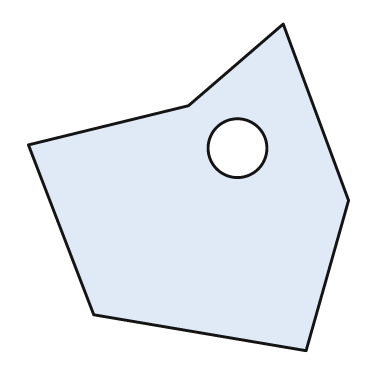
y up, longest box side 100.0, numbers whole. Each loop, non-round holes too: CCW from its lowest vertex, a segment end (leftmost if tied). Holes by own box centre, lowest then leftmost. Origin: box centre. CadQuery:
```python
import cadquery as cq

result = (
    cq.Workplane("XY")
    .moveTo(36.0, -50.0)
    .lineTo(49.0, -4.0)
    .lineTo(29.0, 50.0)
    .lineTo(0.0, 25.0)
    .lineTo(-49.0, 13.0)
    .lineTo(-29.0, -39.0)
    .close()
    .moveTo(15.0, 12.0)
    .circle(9.0)
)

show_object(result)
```